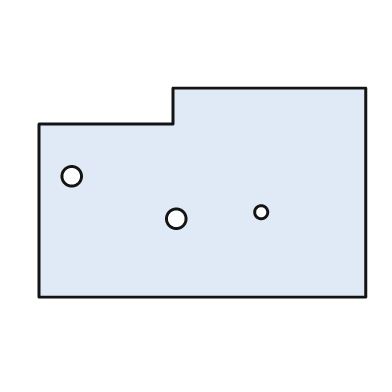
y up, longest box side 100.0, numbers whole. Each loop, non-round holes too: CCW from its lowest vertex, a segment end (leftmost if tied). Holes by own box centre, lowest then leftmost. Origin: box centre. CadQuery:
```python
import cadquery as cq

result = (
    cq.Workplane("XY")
    .moveTo(-50.0, -32.0)
    .lineTo(50.0, -32.0)
    .lineTo(50.0, 32.0)
    .lineTo(-9.0, 32.0)
    .lineTo(-9.0, 21.0)
    .lineTo(-50.0, 21.0)
    .close()
    .moveTo(-8.0, -8.0)
    .circle(3.0)
    .moveTo(18.0, -6.0)
    .circle(2.0)
    .moveTo(-40.0, 5.0)
    .circle(3.0)
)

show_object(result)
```